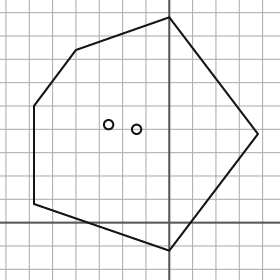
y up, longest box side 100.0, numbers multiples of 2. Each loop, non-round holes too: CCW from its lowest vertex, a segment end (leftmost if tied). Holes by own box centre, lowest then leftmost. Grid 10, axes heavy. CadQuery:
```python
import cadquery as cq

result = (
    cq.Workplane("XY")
    .moveTo(0.0, -12.0)
    .lineTo(38.0, 38.0)
    .lineTo(0.0, 88.0)
    .lineTo(-40.0, 74.0)
    .lineTo(-58.0, 50.0)
    .lineTo(-58.0, 8.0)
    .close()
    .moveTo(-14.0, 40.0)
    .circle(2.0)
    .moveTo(-26.0, 42.0)
    .circle(2.0)
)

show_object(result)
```